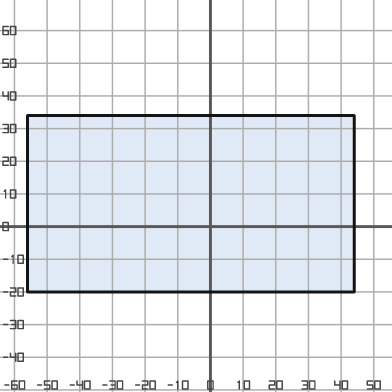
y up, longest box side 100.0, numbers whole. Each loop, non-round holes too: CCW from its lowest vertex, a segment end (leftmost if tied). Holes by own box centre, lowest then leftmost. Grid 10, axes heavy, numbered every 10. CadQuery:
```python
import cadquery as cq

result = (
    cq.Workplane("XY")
    .moveTo(-56.0, -20.0)
    .lineTo(44.0, -20.0)
    .lineTo(44.0, 34.0)
    .lineTo(-56.0, 34.0)
    .close()
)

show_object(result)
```